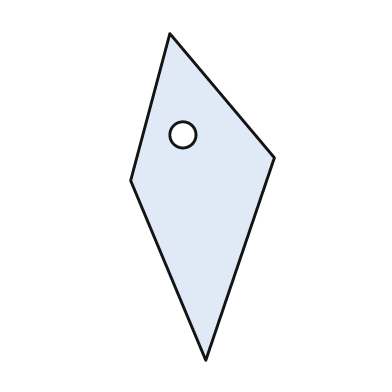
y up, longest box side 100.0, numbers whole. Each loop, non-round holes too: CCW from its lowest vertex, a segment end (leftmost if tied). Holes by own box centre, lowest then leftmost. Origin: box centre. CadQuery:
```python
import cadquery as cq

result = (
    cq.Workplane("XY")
    .moveTo(1.0, -50.0)
    .lineTo(22.0, 12.0)
    .lineTo(-10.0, 50.0)
    .lineTo(-22.0, 5.0)
    .close()
    .moveTo(-6.0, 19.0)
    .circle(4.0)
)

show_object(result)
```